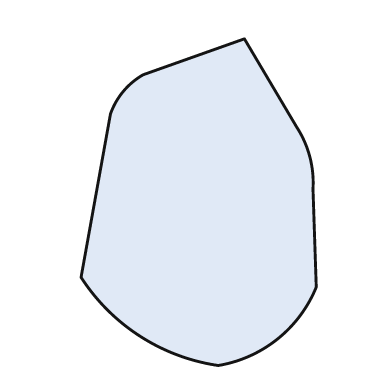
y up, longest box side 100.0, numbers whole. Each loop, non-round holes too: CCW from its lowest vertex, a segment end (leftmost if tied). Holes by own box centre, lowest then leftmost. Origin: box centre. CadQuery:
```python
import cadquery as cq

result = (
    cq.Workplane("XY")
    .moveTo(6.0, -50.0)
    .threePointArc((24.0, -42.0), (36.0, -26.0))
    .lineTo(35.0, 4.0)
    .threePointArc((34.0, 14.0), (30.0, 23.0))
    .lineTo(14.0, 50.0)
    .lineTo(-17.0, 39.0)
    .threePointArc((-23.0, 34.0), (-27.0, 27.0))
    .lineTo(-36.0, -23.0)
    .threePointArc((-18.0, -41.0), (6.0, -50.0))
    .close()
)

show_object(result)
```